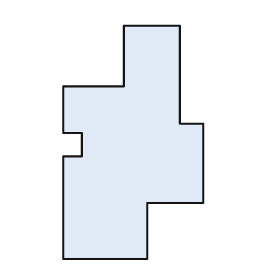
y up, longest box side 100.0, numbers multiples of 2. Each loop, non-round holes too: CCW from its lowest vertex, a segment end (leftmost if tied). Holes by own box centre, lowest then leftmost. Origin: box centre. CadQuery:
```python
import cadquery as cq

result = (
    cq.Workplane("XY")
    .moveTo(-30.0, -50.0)
    .lineTo(6.0, -50.0)
    .lineTo(6.0, -26.0)
    .lineTo(30.0, -26.0)
    .lineTo(30.0, 8.0)
    .lineTo(20.0, 8.0)
    .lineTo(20.0, 50.0)
    .lineTo(-4.0, 50.0)
    .lineTo(-4.0, 24.0)
    .lineTo(-30.0, 24.0)
    .lineTo(-30.0, 4.0)
    .lineTo(-22.0, 4.0)
    .lineTo(-22.0, -6.0)
    .lineTo(-30.0, -6.0)
    .close()
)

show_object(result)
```